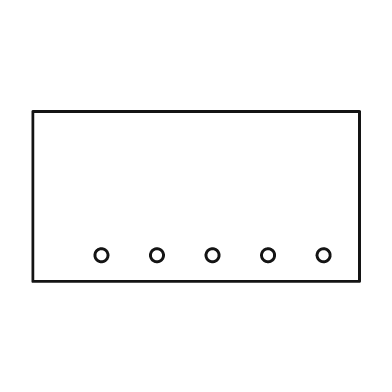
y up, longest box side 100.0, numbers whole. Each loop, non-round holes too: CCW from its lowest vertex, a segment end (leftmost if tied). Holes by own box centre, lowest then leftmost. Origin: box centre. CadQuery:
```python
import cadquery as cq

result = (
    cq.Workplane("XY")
    .moveTo(-50.0, -26.0)
    .lineTo(50.0, -26.0)
    .lineTo(50.0, 26.0)
    .lineTo(-50.0, 26.0)
    .close()
    .moveTo(-29.0, -18.0)
    .circle(2.0)
    .moveTo(-12.0, -18.0)
    .circle(2.0)
    .moveTo(5.0, -18.0)
    .circle(2.0)
    .moveTo(22.0, -18.0)
    .circle(2.0)
    .moveTo(39.0, -18.0)
    .circle(2.0)
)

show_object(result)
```